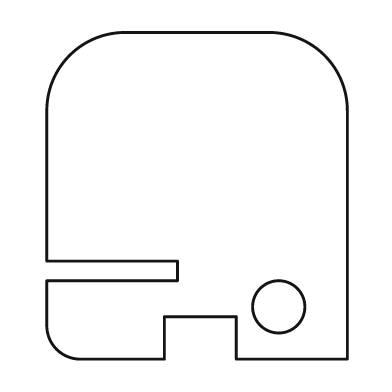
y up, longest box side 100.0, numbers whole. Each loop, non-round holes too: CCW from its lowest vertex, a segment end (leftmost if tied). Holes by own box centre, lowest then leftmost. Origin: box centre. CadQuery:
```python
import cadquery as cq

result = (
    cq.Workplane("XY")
    .moveTo(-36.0, -50.0)
    .lineTo(-10.0, -50.0)
    .lineTo(-10.0, -37.0)
    .lineTo(12.0, -37.0)
    .lineTo(12.0, -50.0)
    .lineTo(46.0, -50.0)
    .lineTo(46.0, 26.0)
    .threePointArc((39.0, 43.0), (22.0, 50.0))
    .lineTo(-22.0, 50.0)
    .threePointArc((-39.0, 43.0), (-46.0, 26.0))
    .lineTo(-46.0, -20.0)
    .lineTo(-6.0, -20.0)
    .lineTo(-6.0, -26.0)
    .lineTo(-46.0, -26.0)
    .lineTo(-46.0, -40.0)
    .threePointArc((-43.0, -47.0), (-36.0, -50.0))
    .close()
    .moveTo(25.0, -34.0)
    .circle(8.0)
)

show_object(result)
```